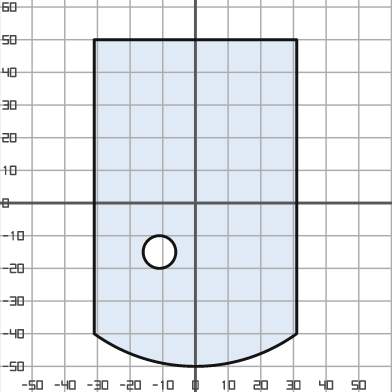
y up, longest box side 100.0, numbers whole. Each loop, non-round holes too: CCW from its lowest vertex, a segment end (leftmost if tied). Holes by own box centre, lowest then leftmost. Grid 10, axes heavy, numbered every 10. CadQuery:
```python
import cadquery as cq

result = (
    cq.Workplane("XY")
    .moveTo(-31.0, -40.0)
    .threePointArc((0.0, -50.0), (31.0, -40.0))
    .lineTo(31.0, 50.0)
    .lineTo(-31.0, 50.0)
    .close()
    .moveTo(-11.0, -15.0)
    .circle(5.0)
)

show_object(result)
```